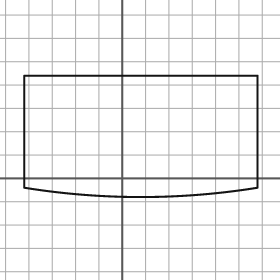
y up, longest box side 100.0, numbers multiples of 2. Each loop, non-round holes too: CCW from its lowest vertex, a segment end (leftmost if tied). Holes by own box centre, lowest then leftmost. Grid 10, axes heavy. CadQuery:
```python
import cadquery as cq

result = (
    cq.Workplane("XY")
    .moveTo(-42.0, -4.0)
    .threePointArc((8.0, -8.0), (58.0, -4.0))
    .lineTo(58.0, 44.0)
    .lineTo(-42.0, 44.0)
    .close()
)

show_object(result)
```